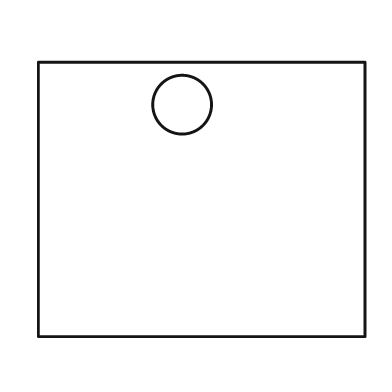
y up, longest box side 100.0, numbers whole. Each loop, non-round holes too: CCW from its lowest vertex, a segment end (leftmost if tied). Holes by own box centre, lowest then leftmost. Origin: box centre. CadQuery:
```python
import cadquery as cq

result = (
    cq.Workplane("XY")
    .moveTo(-50.0, -42.0)
    .lineTo(50.0, -42.0)
    .lineTo(50.0, 42.0)
    .lineTo(-50.0, 42.0)
    .close()
    .moveTo(-6.0, 29.0)
    .circle(9.0)
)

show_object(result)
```